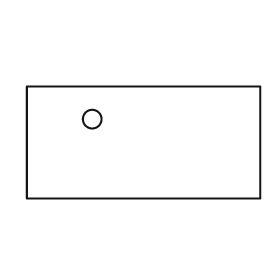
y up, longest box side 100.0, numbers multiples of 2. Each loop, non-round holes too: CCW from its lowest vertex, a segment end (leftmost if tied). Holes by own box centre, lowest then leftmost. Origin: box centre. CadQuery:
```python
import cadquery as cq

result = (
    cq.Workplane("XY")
    .moveTo(-50.0, -24.0)
    .lineTo(50.0, -24.0)
    .lineTo(50.0, 24.0)
    .lineTo(-50.0, 24.0)
    .close()
    .moveTo(-22.0, 10.0)
    .circle(4.0)
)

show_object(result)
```